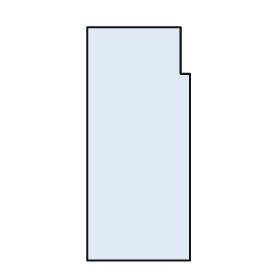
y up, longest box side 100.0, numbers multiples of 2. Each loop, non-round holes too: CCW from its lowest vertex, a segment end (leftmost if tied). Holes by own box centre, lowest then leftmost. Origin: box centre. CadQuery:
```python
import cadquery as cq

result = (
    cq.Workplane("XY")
    .moveTo(-22.0, -50.0)
    .lineTo(22.0, -50.0)
    .lineTo(22.0, 30.0)
    .lineTo(18.0, 30.0)
    .lineTo(18.0, 50.0)
    .lineTo(-22.0, 50.0)
    .close()
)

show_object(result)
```